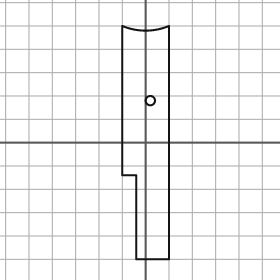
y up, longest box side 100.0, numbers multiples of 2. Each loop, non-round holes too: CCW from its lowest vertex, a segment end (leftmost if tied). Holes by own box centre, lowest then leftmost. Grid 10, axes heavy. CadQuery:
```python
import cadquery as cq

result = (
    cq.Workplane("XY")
    .moveTo(-4.0, -50.0)
    .lineTo(10.0, -50.0)
    .lineTo(10.0, 50.0)
    .threePointArc((0.0, 48.0), (-10.0, 50.0))
    .lineTo(-10.0, -14.0)
    .lineTo(-4.0, -14.0)
    .close()
    .moveTo(2.0, 18.0)
    .circle(2.0)
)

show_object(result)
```